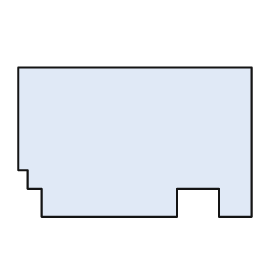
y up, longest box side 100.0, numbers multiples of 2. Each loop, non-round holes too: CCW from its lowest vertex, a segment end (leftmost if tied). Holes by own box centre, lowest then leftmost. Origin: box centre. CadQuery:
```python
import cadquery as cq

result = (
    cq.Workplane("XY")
    .moveTo(-40.0, -32.0)
    .lineTo(18.0, -32.0)
    .lineTo(18.0, -20.0)
    .lineTo(36.0, -20.0)
    .lineTo(36.0, -32.0)
    .lineTo(50.0, -32.0)
    .lineTo(50.0, 32.0)
    .lineTo(-50.0, 32.0)
    .lineTo(-50.0, -12.0)
    .lineTo(-46.0, -12.0)
    .lineTo(-46.0, -20.0)
    .lineTo(-40.0, -20.0)
    .close()
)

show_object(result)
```